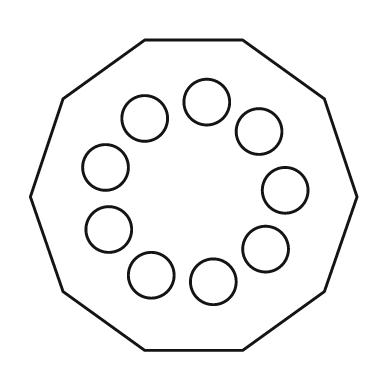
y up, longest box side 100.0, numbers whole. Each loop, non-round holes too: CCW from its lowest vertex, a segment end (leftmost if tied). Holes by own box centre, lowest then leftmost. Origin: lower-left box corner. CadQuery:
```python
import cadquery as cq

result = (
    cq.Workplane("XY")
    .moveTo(35.0, 0.0)
    .lineTo(65.0, 0.0)
    .lineTo(90.0, 18.0)
    .lineTo(100.0, 47.0)
    .lineTo(90.0, 77.0)
    .lineTo(65.0, 95.0)
    .lineTo(35.0, 95.0)
    .lineTo(10.0, 77.0)
    .lineTo(0.0, 47.0)
    .lineTo(10.0, 18.0)
    .close()
    .moveTo(56.0, 21.0)
    .circle(7.0)
    .moveTo(37.0, 23.0)
    .circle(7.0)
    .moveTo(72.0, 31.0)
    .circle(7.0)
    .moveTo(24.0, 37.0)
    .circle(7.0)
    .moveTo(78.0, 49.0)
    .circle(7.0)
    .moveTo(23.0, 56.0)
    .circle(7.0)
    .moveTo(70.0, 67.0)
    .circle(7.0)
    .moveTo(35.0, 71.0)
    .circle(7.0)
    .moveTo(54.0, 76.0)
    .circle(7.0)
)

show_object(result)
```